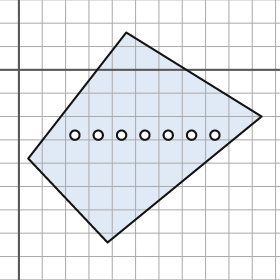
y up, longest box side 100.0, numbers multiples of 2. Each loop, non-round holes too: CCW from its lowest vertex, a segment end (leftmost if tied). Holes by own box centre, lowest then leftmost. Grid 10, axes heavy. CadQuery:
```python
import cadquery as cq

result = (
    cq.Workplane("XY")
    .moveTo(38.0, -74.0)
    .lineTo(104.0, -20.0)
    .lineTo(46.0, 16.0)
    .lineTo(4.0, -38.0)
    .close()
    .moveTo(24.0, -28.0)
    .circle(2.0)
    .moveTo(34.0, -28.0)
    .circle(2.0)
    .moveTo(44.0, -28.0)
    .circle(2.0)
    .moveTo(54.0, -28.0)
    .circle(2.0)
    .moveTo(64.0, -28.0)
    .circle(2.0)
    .moveTo(74.0, -28.0)
    .circle(2.0)
    .moveTo(84.0, -28.0)
    .circle(2.0)
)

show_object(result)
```